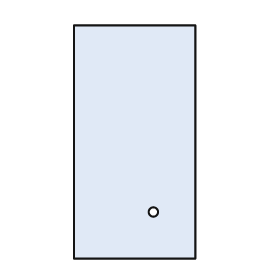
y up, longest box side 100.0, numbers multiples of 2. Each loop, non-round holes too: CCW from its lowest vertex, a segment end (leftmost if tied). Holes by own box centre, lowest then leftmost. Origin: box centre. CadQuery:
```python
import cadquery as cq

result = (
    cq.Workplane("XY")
    .moveTo(-26.0, -50.0)
    .lineTo(26.0, -50.0)
    .lineTo(26.0, 50.0)
    .lineTo(-26.0, 50.0)
    .close()
    .moveTo(8.0, -30.0)
    .circle(2.0)
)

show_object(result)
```